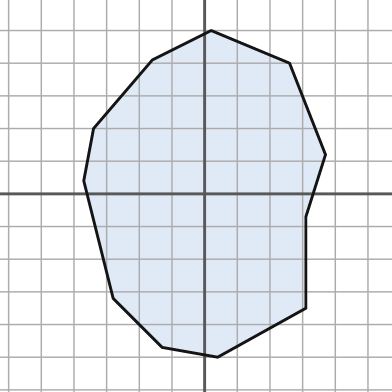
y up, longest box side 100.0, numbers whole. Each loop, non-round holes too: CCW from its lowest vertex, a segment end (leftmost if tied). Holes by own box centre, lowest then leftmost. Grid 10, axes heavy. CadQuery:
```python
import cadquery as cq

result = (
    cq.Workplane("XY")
    .moveTo(4.0, -50.0)
    .lineTo(31.0, -35.0)
    .lineTo(31.0, -7.0)
    .lineTo(37.0, 12.0)
    .lineTo(26.0, 40.0)
    .lineTo(2.0, 50.0)
    .lineTo(-16.0, 41.0)
    .lineTo(-34.0, 20.0)
    .lineTo(-37.0, 4.0)
    .lineTo(-28.0, -32.0)
    .lineTo(-13.0, -47.0)
    .close()
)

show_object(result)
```